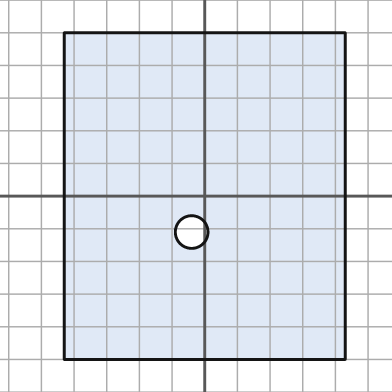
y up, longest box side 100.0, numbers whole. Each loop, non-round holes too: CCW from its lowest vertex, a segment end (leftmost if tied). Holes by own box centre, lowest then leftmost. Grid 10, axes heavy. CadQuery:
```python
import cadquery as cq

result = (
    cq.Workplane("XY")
    .moveTo(-43.0, -50.0)
    .lineTo(43.0, -50.0)
    .lineTo(43.0, 50.0)
    .lineTo(-43.0, 50.0)
    .close()
    .moveTo(-4.0, -11.0)
    .circle(5.0)
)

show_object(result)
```